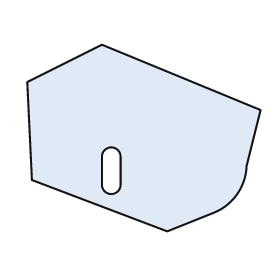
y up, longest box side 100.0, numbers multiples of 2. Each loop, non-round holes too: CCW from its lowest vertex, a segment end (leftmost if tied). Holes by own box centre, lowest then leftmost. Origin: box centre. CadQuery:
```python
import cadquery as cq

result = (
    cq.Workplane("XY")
    .moveTo(10.0, -40.0)
    .lineTo(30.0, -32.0)
    .threePointArc((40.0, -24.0), (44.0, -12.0))
    .lineTo(50.0, 12.0)
    .lineTo(-18.0, 40.0)
    .lineTo(-50.0, 24.0)
    .lineTo(-48.0, -18.0)
    .close()
    .moveTo(-18.0, -20.0)
    .threePointArc((-14.0, -24.0), (-10.0, -20.0))
    .lineTo(-10.0, -8.0)
    .threePointArc((-14.0, -4.0), (-18.0, -8.0))
    .close()
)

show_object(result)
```